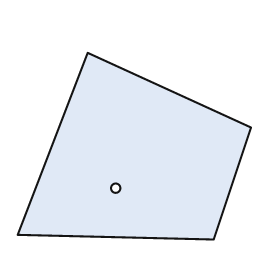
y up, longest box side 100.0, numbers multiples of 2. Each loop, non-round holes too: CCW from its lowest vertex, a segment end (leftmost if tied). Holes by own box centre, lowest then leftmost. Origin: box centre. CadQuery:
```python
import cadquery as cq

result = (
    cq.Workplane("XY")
    .moveTo(34.0, -40.0)
    .lineTo(50.0, 8.0)
    .lineTo(-20.0, 40.0)
    .lineTo(-50.0, -38.0)
    .close()
    .moveTo(-8.0, -18.0)
    .circle(2.0)
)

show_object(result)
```